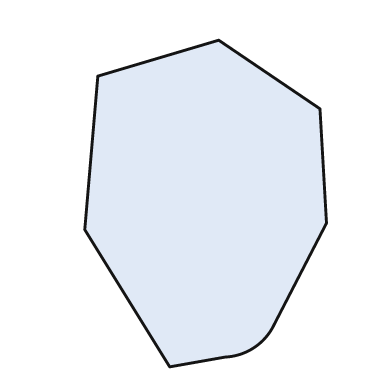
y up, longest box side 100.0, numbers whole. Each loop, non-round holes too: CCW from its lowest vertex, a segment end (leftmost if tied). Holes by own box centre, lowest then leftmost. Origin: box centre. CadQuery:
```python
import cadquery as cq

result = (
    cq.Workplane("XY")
    .moveTo(-11.0, -50.0)
    .lineTo(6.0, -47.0)
    .threePointArc((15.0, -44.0), (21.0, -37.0))
    .lineTo(37.0, -6.0)
    .lineTo(35.0, 29.0)
    .lineTo(4.0, 50.0)
    .lineTo(-33.0, 39.0)
    .lineTo(-37.0, -8.0)
    .close()
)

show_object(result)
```